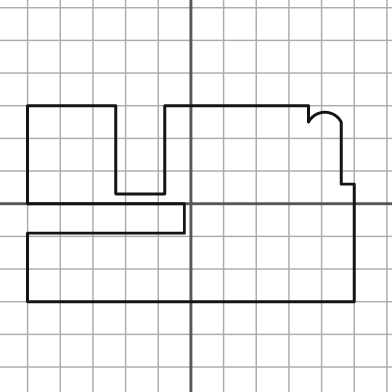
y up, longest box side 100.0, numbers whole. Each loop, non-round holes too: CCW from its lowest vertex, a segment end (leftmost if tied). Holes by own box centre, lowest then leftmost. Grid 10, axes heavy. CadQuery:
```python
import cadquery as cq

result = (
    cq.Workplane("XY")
    .moveTo(-50.0, -30.0)
    .lineTo(50.0, -30.0)
    .lineTo(50.0, 6.0)
    .lineTo(46.0, 6.0)
    .lineTo(46.0, 25.0)
    .threePointArc((41.0, 28.0), (36.0, 25.0))
    .lineTo(36.0, 30.0)
    .lineTo(-8.0, 30.0)
    .lineTo(-8.0, 3.0)
    .lineTo(-23.0, 3.0)
    .lineTo(-23.0, 30.0)
    .lineTo(-50.0, 30.0)
    .lineTo(-50.0, 0.0)
    .lineTo(-2.0, 0.0)
    .lineTo(-2.0, -9.0)
    .lineTo(-50.0, -9.0)
    .close()
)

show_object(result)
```